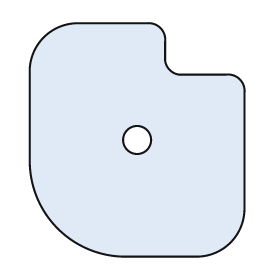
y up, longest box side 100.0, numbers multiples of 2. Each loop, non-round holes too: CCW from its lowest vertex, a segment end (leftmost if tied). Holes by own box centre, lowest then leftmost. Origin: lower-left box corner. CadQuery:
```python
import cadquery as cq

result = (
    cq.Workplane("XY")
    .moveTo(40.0, 0.0)
    .lineTo(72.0, 0.0)
    .threePointArc((86.0, 6.0), (92.0, 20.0))
    .lineTo(92.0, 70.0)
    .threePointArc((90.0, 76.0), (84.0, 78.0))
    .lineTo(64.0, 78.0)
    .threePointArc((60.0, 80.0), (58.0, 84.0))
    .lineTo(58.0, 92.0)
    .threePointArc((56.0, 98.0), (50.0, 100.0))
    .lineTo(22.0, 100.0)
    .threePointArc((6.0, 94.0), (0.0, 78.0))
    .lineTo(0.0, 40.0)
    .threePointArc((12.0, 12.0), (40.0, 0.0))
    .close()
    .moveTo(46.0, 50.0)
    .circle(6.0)
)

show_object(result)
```